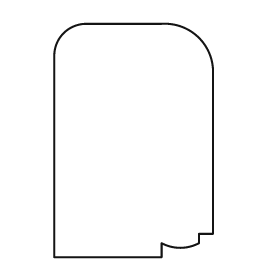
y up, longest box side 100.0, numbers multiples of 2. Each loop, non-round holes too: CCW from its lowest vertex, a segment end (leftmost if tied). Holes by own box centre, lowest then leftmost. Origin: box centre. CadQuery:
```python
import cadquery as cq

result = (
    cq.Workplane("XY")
    .moveTo(-34.0, -50.0)
    .lineTo(12.0, -50.0)
    .lineTo(12.0, -44.0)
    .threePointArc((20.0, -46.0), (28.0, -44.0))
    .lineTo(28.0, -40.0)
    .lineTo(34.0, -40.0)
    .lineTo(34.0, 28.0)
    .threePointArc((28.0, 44.0), (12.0, 50.0))
    .lineTo(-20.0, 50.0)
    .threePointArc((-30.0, 46.0), (-34.0, 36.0))
    .close()
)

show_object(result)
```